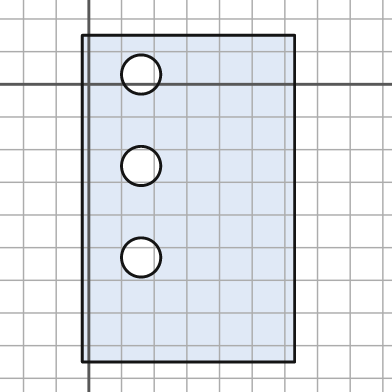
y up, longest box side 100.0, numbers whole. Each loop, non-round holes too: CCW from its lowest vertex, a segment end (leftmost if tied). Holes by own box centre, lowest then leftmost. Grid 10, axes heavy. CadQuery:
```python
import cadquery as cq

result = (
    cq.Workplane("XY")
    .moveTo(-2.0, -85.0)
    .lineTo(63.0, -85.0)
    .lineTo(63.0, 15.0)
    .lineTo(-2.0, 15.0)
    .close()
    .moveTo(16.0, -53.0)
    .circle(6.0)
    .moveTo(16.0, -25.0)
    .circle(6.0)
    .moveTo(16.0, 3.0)
    .circle(6.0)
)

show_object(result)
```